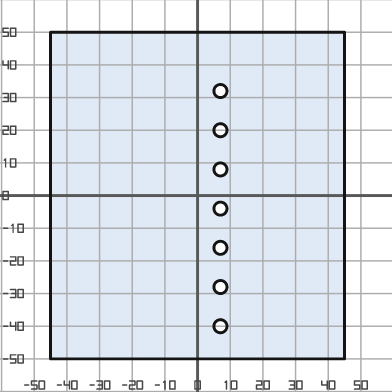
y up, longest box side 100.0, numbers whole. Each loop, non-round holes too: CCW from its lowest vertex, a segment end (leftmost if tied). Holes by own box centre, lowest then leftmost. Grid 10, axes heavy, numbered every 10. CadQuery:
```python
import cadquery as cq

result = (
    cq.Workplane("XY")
    .moveTo(-45.0, -50.0)
    .lineTo(45.0, -50.0)
    .lineTo(45.0, 50.0)
    .lineTo(-45.0, 50.0)
    .close()
    .moveTo(7.0, -40.0)
    .circle(2.0)
    .moveTo(7.0, -28.0)
    .circle(2.0)
    .moveTo(7.0, -16.0)
    .circle(2.0)
    .moveTo(7.0, -4.0)
    .circle(2.0)
    .moveTo(7.0, 8.0)
    .circle(2.0)
    .moveTo(7.0, 20.0)
    .circle(2.0)
    .moveTo(7.0, 32.0)
    .circle(2.0)
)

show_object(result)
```